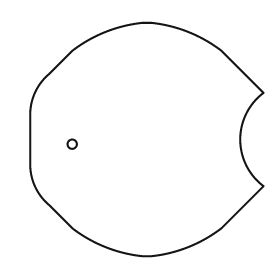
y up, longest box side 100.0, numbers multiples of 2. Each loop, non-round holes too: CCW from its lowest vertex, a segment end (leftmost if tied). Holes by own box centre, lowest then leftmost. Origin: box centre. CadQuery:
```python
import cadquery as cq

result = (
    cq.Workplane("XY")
    .moveTo(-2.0, -50.0)
    .lineTo(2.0, -50.0)
    .threePointArc((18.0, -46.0), (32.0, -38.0))
    .lineTo(50.0, -20.0)
    .threePointArc((40.0, 0.0), (50.0, 20.0))
    .lineTo(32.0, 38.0)
    .threePointArc((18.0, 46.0), (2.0, 50.0))
    .lineTo(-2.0, 50.0)
    .threePointArc((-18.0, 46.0), (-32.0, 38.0))
    .lineTo(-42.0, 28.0)
    .threePointArc((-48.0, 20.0), (-50.0, 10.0))
    .lineTo(-50.0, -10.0)
    .threePointArc((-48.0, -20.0), (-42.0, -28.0))
    .lineTo(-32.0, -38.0)
    .threePointArc((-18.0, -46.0), (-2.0, -50.0))
    .close()
    .moveTo(-32.0, -2.0)
    .circle(2.0)
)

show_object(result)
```